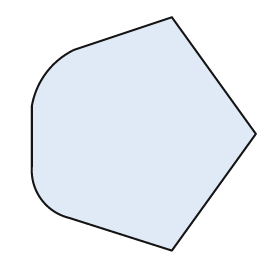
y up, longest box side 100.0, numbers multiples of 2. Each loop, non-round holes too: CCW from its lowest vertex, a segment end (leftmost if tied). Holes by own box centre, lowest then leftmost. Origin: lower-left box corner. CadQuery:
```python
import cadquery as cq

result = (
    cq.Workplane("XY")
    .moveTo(60.0, 0.0)
    .lineTo(96.0, 50.0)
    .lineTo(60.0, 100.0)
    .lineTo(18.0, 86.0)
    .threePointArc((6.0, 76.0), (0.0, 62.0))
    .lineTo(0.0, 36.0)
    .threePointArc((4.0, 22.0), (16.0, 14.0))
    .close()
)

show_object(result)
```